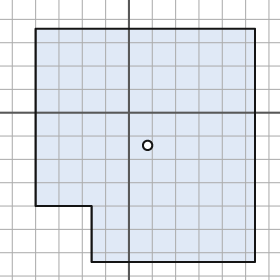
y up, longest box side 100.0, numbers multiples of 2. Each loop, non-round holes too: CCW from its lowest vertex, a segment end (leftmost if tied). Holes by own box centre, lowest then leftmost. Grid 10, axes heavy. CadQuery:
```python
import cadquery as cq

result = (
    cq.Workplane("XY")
    .moveTo(-16.0, -64.0)
    .lineTo(54.0, -64.0)
    .lineTo(54.0, 36.0)
    .lineTo(-40.0, 36.0)
    .lineTo(-40.0, -40.0)
    .lineTo(-16.0, -40.0)
    .close()
    .moveTo(8.0, -14.0)
    .circle(2.0)
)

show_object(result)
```